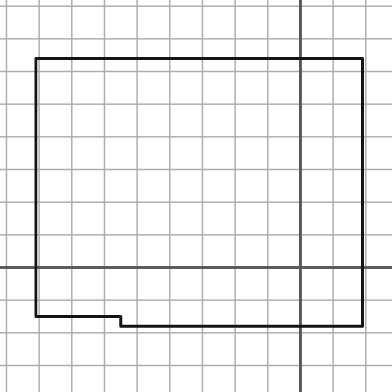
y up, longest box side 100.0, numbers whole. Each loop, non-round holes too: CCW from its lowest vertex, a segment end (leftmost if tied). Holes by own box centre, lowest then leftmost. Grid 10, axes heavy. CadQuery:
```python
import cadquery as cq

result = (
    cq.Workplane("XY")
    .moveTo(-55.0, -18.0)
    .lineTo(19.0, -18.0)
    .lineTo(19.0, 64.0)
    .lineTo(-81.0, 64.0)
    .lineTo(-81.0, -15.0)
    .lineTo(-55.0, -15.0)
    .close()
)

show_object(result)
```